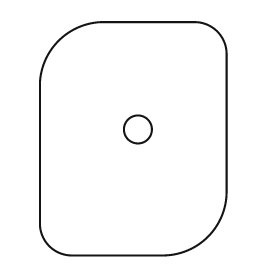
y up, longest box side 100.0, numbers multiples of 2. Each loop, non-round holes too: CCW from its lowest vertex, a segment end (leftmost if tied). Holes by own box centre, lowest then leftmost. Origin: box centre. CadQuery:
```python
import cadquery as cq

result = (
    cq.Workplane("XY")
    .moveTo(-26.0, -50.0)
    .lineTo(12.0, -50.0)
    .threePointArc((32.0, -42.0), (40.0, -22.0))
    .lineTo(40.0, 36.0)
    .threePointArc((36.0, 46.0), (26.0, 50.0))
    .lineTo(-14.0, 50.0)
    .threePointArc((-32.0, 42.0), (-40.0, 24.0))
    .lineTo(-40.0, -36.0)
    .threePointArc((-36.0, -46.0), (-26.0, -50.0))
    .close()
    .moveTo(2.0, 4.0)
    .circle(6.0)
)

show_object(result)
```